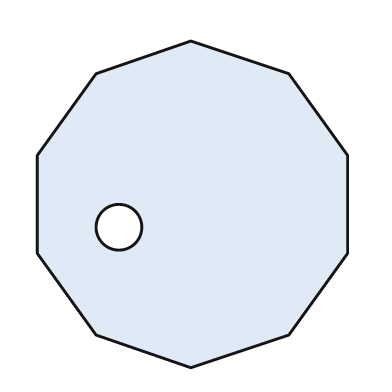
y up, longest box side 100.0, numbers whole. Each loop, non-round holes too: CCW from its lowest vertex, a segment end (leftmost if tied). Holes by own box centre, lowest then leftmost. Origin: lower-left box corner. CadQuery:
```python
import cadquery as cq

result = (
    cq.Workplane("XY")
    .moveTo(47.0, 0.0)
    .lineTo(77.0, 10.0)
    .lineTo(95.0, 35.0)
    .lineTo(95.0, 65.0)
    .lineTo(77.0, 90.0)
    .lineTo(47.0, 100.0)
    .lineTo(18.0, 90.0)
    .lineTo(0.0, 65.0)
    .lineTo(0.0, 35.0)
    .lineTo(18.0, 10.0)
    .close()
    .moveTo(25.0, 43.0)
    .circle(7.0)
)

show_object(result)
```